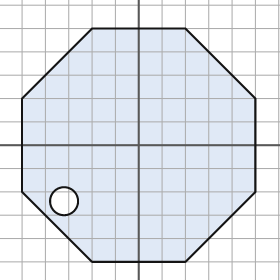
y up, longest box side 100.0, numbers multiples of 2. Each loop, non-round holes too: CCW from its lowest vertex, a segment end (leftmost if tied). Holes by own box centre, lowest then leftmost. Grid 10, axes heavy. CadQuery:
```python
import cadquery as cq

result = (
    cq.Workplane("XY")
    .moveTo(-20.0, -50.0)
    .lineTo(20.0, -50.0)
    .lineTo(50.0, -20.0)
    .lineTo(50.0, 20.0)
    .lineTo(20.0, 50.0)
    .lineTo(-20.0, 50.0)
    .lineTo(-50.0, 20.0)
    .lineTo(-50.0, -20.0)
    .close()
    .moveTo(-32.0, -24.0)
    .circle(6.0)
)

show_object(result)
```